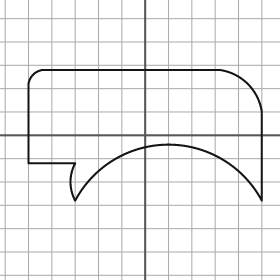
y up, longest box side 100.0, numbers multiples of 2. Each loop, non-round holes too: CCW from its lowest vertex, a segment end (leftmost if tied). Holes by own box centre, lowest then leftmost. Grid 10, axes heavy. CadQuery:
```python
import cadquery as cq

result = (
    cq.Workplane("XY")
    .moveTo(-30.0, -28.0)
    .threePointArc((10.0, -4.0), (50.0, -28.0))
    .lineTo(50.0, 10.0)
    .threePointArc((44.0, 22.0), (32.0, 28.0))
    .lineTo(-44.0, 28.0)
    .threePointArc((-48.0, 26.0), (-50.0, 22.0))
    .lineTo(-50.0, -12.0)
    .lineTo(-30.0, -12.0)
    .threePointArc((-32.0, -20.0), (-30.0, -28.0))
    .close()
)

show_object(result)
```